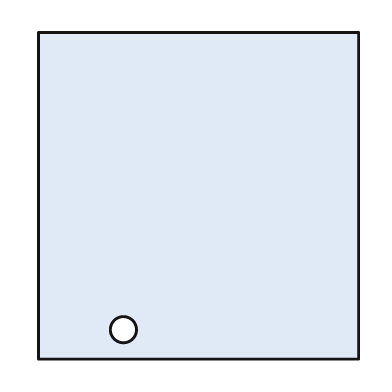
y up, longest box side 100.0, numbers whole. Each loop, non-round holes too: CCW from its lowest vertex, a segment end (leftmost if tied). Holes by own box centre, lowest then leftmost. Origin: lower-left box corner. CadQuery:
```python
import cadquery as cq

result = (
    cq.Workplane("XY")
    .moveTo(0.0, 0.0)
    .lineTo(98.0, 0.0)
    .lineTo(98.0, 100.0)
    .lineTo(0.0, 100.0)
    .close()
    .moveTo(26.0, 9.0)
    .circle(4.0)
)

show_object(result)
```